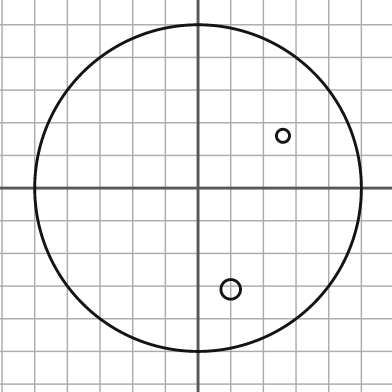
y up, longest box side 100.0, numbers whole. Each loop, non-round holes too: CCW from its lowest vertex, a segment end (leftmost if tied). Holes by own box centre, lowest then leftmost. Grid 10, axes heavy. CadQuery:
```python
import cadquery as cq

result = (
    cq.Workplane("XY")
    .moveTo(0.0, 0.0)
    .circle(50.0)
    .moveTo(10.0, -31.0)
    .circle(3.0)
    .moveTo(26.0, 16.0)
    .circle(2.0)
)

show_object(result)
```